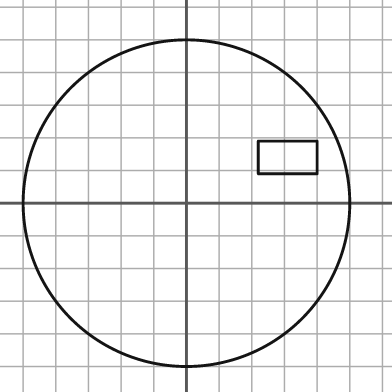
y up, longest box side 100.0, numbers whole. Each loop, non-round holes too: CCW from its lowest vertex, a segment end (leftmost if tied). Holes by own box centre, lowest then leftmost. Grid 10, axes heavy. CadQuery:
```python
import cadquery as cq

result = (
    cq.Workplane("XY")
    .moveTo(0.0, 0.0)
    .circle(50.0)
    .moveTo(22.0, 9.0)
    .lineTo(40.0, 9.0)
    .lineTo(40.0, 19.0)
    .lineTo(22.0, 19.0)
    .close()
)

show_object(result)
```